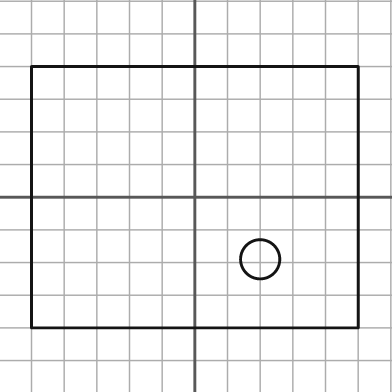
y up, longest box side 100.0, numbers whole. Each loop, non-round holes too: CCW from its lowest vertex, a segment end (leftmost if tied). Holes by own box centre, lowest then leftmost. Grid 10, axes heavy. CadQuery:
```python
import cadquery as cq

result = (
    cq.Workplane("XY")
    .moveTo(-50.0, -40.0)
    .lineTo(50.0, -40.0)
    .lineTo(50.0, 40.0)
    .lineTo(-50.0, 40.0)
    .close()
    .moveTo(20.0, -19.0)
    .circle(6.0)
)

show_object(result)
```